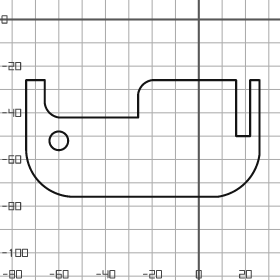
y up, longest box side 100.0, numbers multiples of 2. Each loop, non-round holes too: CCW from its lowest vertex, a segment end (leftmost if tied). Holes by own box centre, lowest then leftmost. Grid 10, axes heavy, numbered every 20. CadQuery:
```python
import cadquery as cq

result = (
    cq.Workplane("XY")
    .moveTo(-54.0, -76.0)
    .lineTo(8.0, -76.0)
    .threePointArc((20.0, -70.0), (26.0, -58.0))
    .lineTo(26.0, -26.0)
    .lineTo(22.0, -26.0)
    .lineTo(22.0, -50.0)
    .lineTo(16.0, -50.0)
    .lineTo(16.0, -26.0)
    .lineTo(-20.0, -26.0)
    .threePointArc((-24.0, -28.0), (-26.0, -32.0))
    .lineTo(-26.0, -42.0)
    .lineTo(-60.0, -42.0)
    .threePointArc((-64.0, -40.0), (-66.0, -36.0))
    .lineTo(-66.0, -26.0)
    .lineTo(-74.0, -26.0)
    .lineTo(-74.0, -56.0)
    .threePointArc((-68.0, -70.0), (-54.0, -76.0))
    .close()
    .moveTo(-60.0, -52.0)
    .circle(4.0)
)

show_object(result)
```